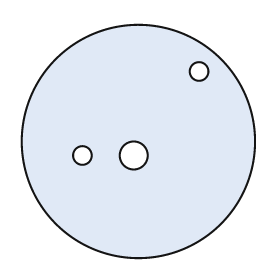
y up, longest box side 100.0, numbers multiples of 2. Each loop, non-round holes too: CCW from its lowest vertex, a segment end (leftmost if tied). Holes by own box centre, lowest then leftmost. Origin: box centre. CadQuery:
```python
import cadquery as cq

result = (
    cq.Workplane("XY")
    .moveTo(0.0, 0.0)
    .circle(50.0)
    .moveTo(-24.0, -6.0)
    .circle(4.0)
    .moveTo(-2.0, -6.0)
    .circle(6.0)
    .moveTo(26.0, 30.0)
    .circle(4.0)
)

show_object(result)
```